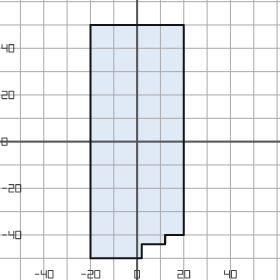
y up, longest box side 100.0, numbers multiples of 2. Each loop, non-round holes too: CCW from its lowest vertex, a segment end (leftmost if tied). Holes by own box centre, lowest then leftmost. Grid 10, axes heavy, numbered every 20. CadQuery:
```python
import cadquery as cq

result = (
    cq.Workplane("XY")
    .moveTo(-20.0, -50.0)
    .lineTo(2.0, -50.0)
    .lineTo(2.0, -44.0)
    .lineTo(12.0, -44.0)
    .lineTo(12.0, -40.0)
    .lineTo(20.0, -40.0)
    .lineTo(20.0, 50.0)
    .lineTo(-20.0, 50.0)
    .close()
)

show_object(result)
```